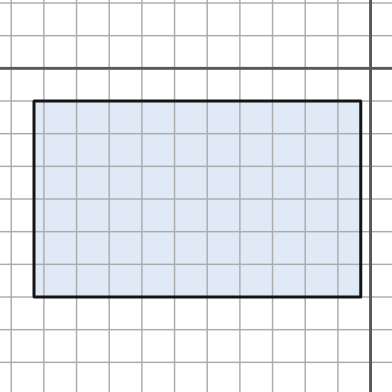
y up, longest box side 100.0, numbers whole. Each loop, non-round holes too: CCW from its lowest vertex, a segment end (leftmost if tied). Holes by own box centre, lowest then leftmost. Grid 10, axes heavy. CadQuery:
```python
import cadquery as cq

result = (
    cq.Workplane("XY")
    .moveTo(-103.0, -70.0)
    .lineTo(-3.0, -70.0)
    .lineTo(-3.0, -10.0)
    .lineTo(-103.0, -10.0)
    .close()
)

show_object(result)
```